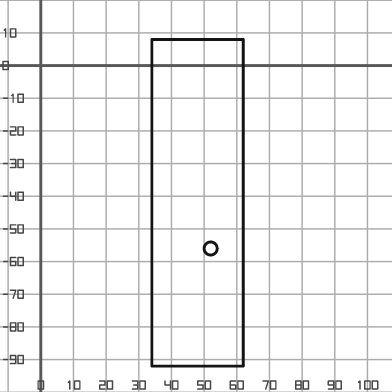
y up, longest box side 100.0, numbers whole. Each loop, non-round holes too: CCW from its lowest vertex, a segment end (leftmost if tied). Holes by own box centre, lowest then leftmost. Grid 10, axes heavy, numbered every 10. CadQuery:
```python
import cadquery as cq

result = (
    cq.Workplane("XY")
    .moveTo(34.0, -92.0)
    .lineTo(62.0, -92.0)
    .lineTo(62.0, 8.0)
    .lineTo(34.0, 8.0)
    .close()
    .moveTo(52.0, -56.0)
    .circle(2.0)
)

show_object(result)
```